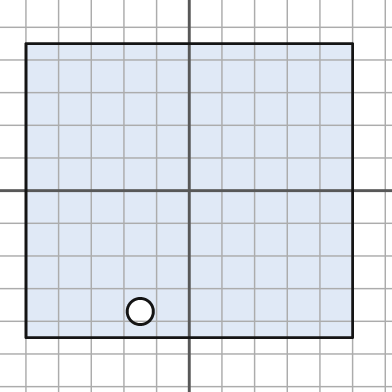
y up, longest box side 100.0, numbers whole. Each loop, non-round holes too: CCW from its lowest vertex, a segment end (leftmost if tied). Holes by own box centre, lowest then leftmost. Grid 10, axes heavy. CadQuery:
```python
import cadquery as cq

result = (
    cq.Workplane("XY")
    .moveTo(-50.0, -45.0)
    .lineTo(50.0, -45.0)
    .lineTo(50.0, 45.0)
    .lineTo(-50.0, 45.0)
    .close()
    .moveTo(-15.0, -37.0)
    .circle(4.0)
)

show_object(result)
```